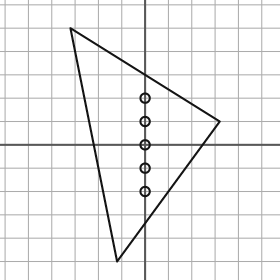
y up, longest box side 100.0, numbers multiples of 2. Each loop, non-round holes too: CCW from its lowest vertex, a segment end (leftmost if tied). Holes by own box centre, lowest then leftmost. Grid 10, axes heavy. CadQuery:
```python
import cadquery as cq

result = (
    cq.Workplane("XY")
    .moveTo(-12.0, -50.0)
    .lineTo(32.0, 10.0)
    .lineTo(-32.0, 50.0)
    .close()
    .moveTo(0.0, -20.0)
    .circle(2.0)
    .moveTo(0.0, -10.0)
    .circle(2.0)
    .moveTo(0.0, 0.0)
    .circle(2.0)
    .moveTo(0.0, 10.0)
    .circle(2.0)
    .moveTo(0.0, 20.0)
    .circle(2.0)
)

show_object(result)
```